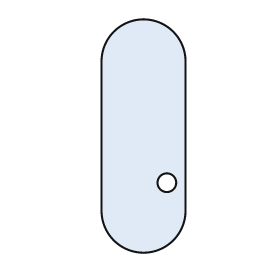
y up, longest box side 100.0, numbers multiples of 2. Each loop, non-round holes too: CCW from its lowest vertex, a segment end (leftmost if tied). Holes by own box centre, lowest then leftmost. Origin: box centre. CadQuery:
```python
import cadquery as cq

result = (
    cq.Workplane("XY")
    .moveTo(-18.0, -32.0)
    .threePointArc((0.0, -50.0), (18.0, -32.0))
    .lineTo(18.0, 32.0)
    .threePointArc((0.0, 50.0), (-18.0, 32.0))
    .close()
    .moveTo(10.0, -20.0)
    .circle(4.0)
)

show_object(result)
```